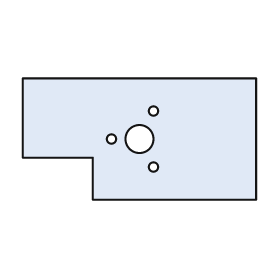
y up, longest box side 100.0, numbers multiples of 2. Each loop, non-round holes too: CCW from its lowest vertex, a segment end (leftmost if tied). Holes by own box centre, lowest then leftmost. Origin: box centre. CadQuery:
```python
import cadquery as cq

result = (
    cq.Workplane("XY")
    .moveTo(-20.0, -26.0)
    .lineTo(50.0, -26.0)
    .lineTo(50.0, 26.0)
    .lineTo(-50.0, 26.0)
    .lineTo(-50.0, -8.0)
    .lineTo(-20.0, -8.0)
    .close()
    .moveTo(6.0, -12.0)
    .circle(2.0)
    .moveTo(-12.0, 0.0)
    .circle(2.0)
    .moveTo(0.0, 0.0)
    .circle(6.0)
    .moveTo(6.0, 12.0)
    .circle(2.0)
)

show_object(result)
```